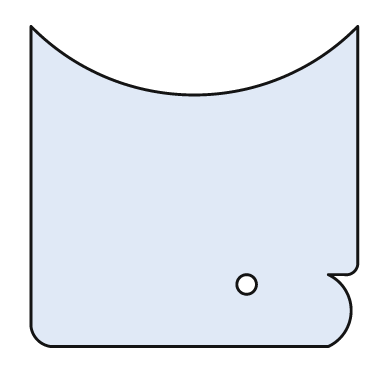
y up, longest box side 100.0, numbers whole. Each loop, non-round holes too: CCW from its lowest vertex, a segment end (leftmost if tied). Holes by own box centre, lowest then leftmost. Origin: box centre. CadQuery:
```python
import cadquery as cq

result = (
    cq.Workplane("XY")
    .moveTo(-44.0, -49.0)
    .lineTo(41.0, -49.0)
    .threePointArc((48.0, -38.0), (41.0, -27.0))
    .lineTo(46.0, -27.0)
    .threePointArc((49.0, -26.0), (50.0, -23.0))
    .lineTo(50.0, 49.0)
    .threePointArc((0.0, 28.0), (-50.0, 49.0))
    .lineTo(-50.0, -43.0)
    .threePointArc((-48.0, -47.0), (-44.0, -49.0))
    .close()
    .moveTo(16.0, -30.0)
    .circle(3.0)
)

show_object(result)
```